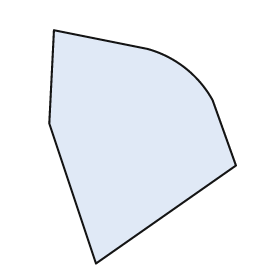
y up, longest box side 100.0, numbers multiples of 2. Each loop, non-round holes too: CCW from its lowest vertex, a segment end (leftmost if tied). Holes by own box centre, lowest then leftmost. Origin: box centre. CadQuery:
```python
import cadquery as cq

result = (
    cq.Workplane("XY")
    .moveTo(-20.0, -50.0)
    .lineTo(40.0, -8.0)
    .lineTo(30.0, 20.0)
    .threePointArc((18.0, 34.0), (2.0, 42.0))
    .lineTo(-38.0, 50.0)
    .lineTo(-40.0, 10.0)
    .close()
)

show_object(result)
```